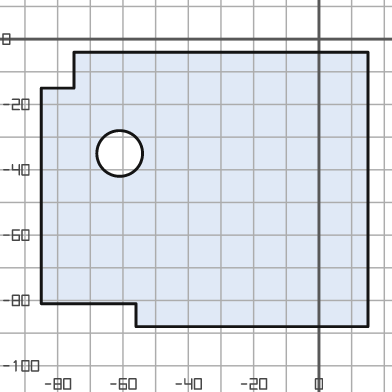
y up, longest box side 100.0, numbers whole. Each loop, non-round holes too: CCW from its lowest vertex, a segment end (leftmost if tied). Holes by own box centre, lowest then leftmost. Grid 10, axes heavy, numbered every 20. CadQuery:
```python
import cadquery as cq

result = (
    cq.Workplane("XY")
    .moveTo(-56.0, -88.0)
    .lineTo(15.0, -88.0)
    .lineTo(15.0, -4.0)
    .lineTo(-75.0, -4.0)
    .lineTo(-75.0, -15.0)
    .lineTo(-85.0, -15.0)
    .lineTo(-85.0, -81.0)
    .lineTo(-56.0, -81.0)
    .close()
    .moveTo(-61.0, -35.0)
    .circle(7.0)
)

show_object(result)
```